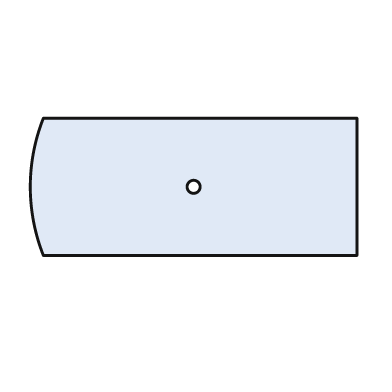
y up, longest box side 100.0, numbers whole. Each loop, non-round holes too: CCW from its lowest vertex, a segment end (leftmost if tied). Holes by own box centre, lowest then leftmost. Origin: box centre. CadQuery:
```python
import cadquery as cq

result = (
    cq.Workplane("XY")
    .moveTo(-46.0, -21.0)
    .lineTo(50.0, -21.0)
    .lineTo(50.0, 21.0)
    .lineTo(-46.0, 21.0)
    .threePointArc((-50.0, 0.0), (-46.0, -21.0))
    .close()
    .moveTo(0.0, 0.0)
    .circle(2.0)
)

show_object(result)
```